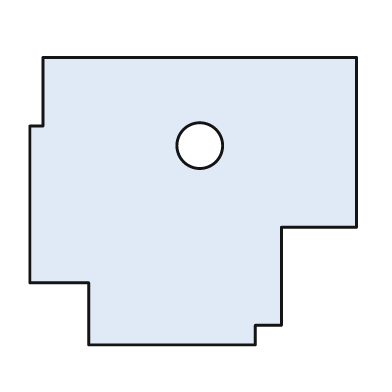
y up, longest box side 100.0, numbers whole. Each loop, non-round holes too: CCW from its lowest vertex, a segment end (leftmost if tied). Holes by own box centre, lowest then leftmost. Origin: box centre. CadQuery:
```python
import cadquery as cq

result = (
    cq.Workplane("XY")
    .moveTo(-32.0, -44.0)
    .lineTo(19.0, -44.0)
    .lineTo(19.0, -38.0)
    .lineTo(27.0, -38.0)
    .lineTo(27.0, -8.0)
    .lineTo(50.0, -8.0)
    .lineTo(50.0, 44.0)
    .lineTo(-46.0, 44.0)
    .lineTo(-46.0, 23.0)
    .lineTo(-50.0, 23.0)
    .lineTo(-50.0, -25.0)
    .lineTo(-32.0, -25.0)
    .close()
    .moveTo(2.0, 17.0)
    .circle(7.0)
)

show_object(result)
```